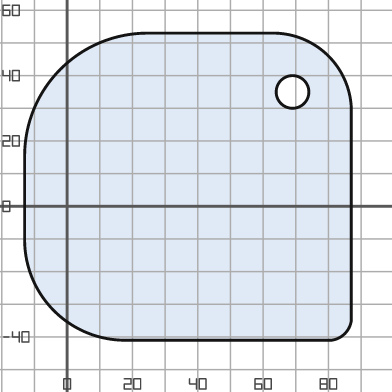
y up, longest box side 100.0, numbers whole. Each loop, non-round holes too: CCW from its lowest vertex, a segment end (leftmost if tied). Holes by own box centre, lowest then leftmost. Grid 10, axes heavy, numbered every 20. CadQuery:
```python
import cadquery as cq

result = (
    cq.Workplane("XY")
    .moveTo(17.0, -41.0)
    .lineTo(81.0, -41.0)
    .threePointArc((85.0, -39.0), (87.0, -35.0))
    .lineTo(87.0, 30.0)
    .threePointArc((80.0, 46.0), (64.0, 53.0))
    .lineTo(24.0, 53.0)
    .threePointArc((-2.0, 42.0), (-13.0, 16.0))
    .lineTo(-13.0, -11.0)
    .threePointArc((-4.0, -32.0), (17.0, -41.0))
    .close()
    .moveTo(69.0, 35.0)
    .circle(5.0)
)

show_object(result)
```